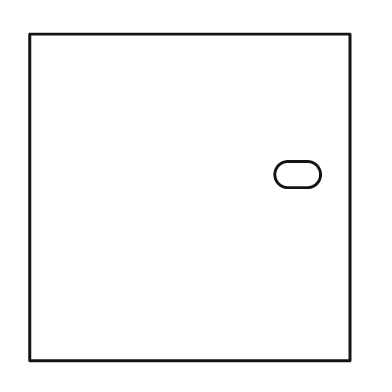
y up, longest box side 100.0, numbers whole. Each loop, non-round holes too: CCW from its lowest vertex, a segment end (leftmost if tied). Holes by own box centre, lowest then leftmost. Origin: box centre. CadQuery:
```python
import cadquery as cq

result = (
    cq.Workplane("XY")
    .moveTo(-49.0, -50.0)
    .lineTo(49.0, -50.0)
    .lineTo(49.0, 50.0)
    .lineTo(-49.0, 50.0)
    .close()
    .moveTo(30.0, 3.0)
    .lineTo(36.0, 3.0)
    .threePointArc((40.0, 7.0), (36.0, 11.0))
    .lineTo(30.0, 11.0)
    .threePointArc((26.0, 7.0), (30.0, 3.0))
    .close()
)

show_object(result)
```